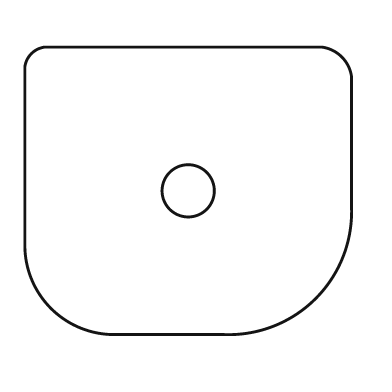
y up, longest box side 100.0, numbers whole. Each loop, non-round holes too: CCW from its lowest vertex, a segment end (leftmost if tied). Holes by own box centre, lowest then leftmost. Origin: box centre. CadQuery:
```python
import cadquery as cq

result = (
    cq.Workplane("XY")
    .moveTo(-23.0, -44.0)
    .lineTo(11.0, -44.0)
    .threePointArc((39.0, -33.0), (50.0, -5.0))
    .lineTo(50.0, 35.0)
    .threePointArc((47.0, 41.0), (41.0, 44.0))
    .lineTo(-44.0, 44.0)
    .threePointArc((-48.0, 42.0), (-50.0, 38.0))
    .lineTo(-50.0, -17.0)
    .threePointArc((-42.0, -36.0), (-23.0, -44.0))
    .close()
    .moveTo(0.0, 0.0)
    .circle(8.0)
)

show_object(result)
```